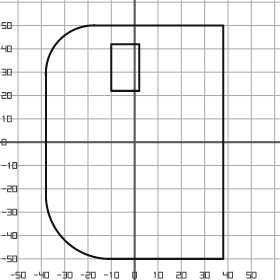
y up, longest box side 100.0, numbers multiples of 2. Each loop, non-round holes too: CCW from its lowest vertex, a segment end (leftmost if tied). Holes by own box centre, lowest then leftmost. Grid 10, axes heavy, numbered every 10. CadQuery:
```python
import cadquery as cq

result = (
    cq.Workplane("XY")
    .moveTo(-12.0, -50.0)
    .lineTo(38.0, -50.0)
    .lineTo(38.0, 50.0)
    .lineTo(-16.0, 50.0)
    .threePointArc((-32.0, 44.0), (-38.0, 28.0))
    .lineTo(-38.0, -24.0)
    .threePointArc((-30.0, -42.0), (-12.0, -50.0))
    .close()
    .moveTo(-10.0, 22.0)
    .lineTo(2.0, 22.0)
    .lineTo(2.0, 42.0)
    .lineTo(-10.0, 42.0)
    .close()
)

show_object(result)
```